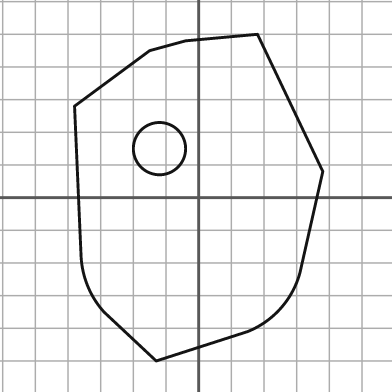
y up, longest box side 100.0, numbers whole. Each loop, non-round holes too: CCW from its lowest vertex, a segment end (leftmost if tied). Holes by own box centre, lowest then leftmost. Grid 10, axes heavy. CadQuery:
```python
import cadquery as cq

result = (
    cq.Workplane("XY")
    .moveTo(-13.0, -50.0)
    .lineTo(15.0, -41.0)
    .threePointArc((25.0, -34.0), (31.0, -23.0))
    .lineTo(38.0, 8.0)
    .lineTo(18.0, 50.0)
    .lineTo(-4.0, 48.0)
    .lineTo(-15.0, 45.0)
    .lineTo(-38.0, 28.0)
    .lineTo(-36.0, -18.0)
    .threePointArc((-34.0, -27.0), (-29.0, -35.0))
    .close()
    .moveTo(-12.0, 15.0)
    .circle(8.0)
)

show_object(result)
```